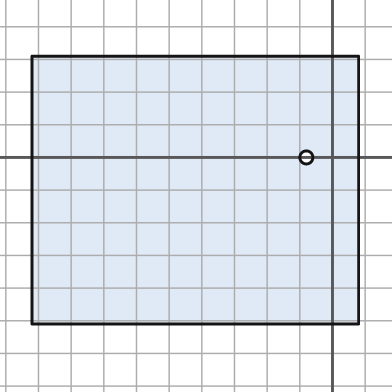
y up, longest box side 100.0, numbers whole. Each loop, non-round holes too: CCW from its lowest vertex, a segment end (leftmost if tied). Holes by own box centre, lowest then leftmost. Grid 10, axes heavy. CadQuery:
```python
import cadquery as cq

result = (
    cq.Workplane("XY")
    .moveTo(-92.0, -51.0)
    .lineTo(8.0, -51.0)
    .lineTo(8.0, 31.0)
    .lineTo(-92.0, 31.0)
    .close()
    .moveTo(-8.0, 0.0)
    .circle(2.0)
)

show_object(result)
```